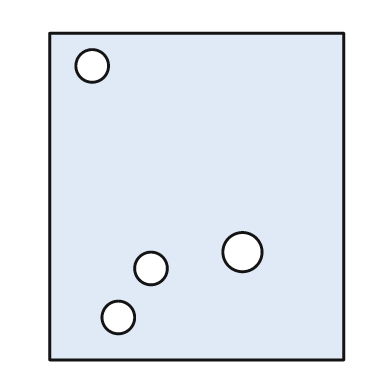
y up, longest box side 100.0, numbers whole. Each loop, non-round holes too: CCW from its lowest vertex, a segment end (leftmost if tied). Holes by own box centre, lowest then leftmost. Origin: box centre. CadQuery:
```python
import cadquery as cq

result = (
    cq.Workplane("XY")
    .moveTo(-45.0, -50.0)
    .lineTo(45.0, -50.0)
    .lineTo(45.0, 50.0)
    .lineTo(-45.0, 50.0)
    .close()
    .moveTo(-24.0, -37.0)
    .circle(5.0)
    .moveTo(-14.0, -22.0)
    .circle(5.0)
    .moveTo(14.0, -17.0)
    .circle(6.0)
    .moveTo(-32.0, 40.0)
    .circle(5.0)
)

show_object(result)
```